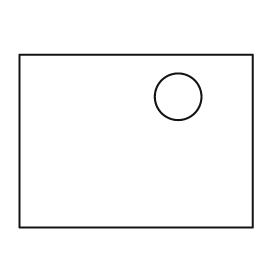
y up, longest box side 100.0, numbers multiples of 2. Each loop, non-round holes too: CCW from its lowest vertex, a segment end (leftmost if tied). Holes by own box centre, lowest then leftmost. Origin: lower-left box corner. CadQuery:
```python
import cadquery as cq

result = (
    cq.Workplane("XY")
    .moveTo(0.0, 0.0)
    .lineTo(100.0, 0.0)
    .lineTo(100.0, 74.0)
    .lineTo(0.0, 74.0)
    .close()
    .moveTo(68.0, 56.0)
    .circle(10.0)
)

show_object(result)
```